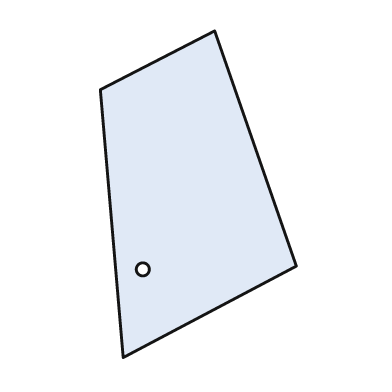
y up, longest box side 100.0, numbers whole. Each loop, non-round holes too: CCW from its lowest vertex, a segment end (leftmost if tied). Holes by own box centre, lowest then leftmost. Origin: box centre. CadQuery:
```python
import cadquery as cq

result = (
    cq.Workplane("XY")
    .moveTo(-23.0, -50.0)
    .lineTo(30.0, -22.0)
    .lineTo(5.0, 50.0)
    .lineTo(-30.0, 32.0)
    .close()
    .moveTo(-17.0, -23.0)
    .circle(2.0)
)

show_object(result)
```